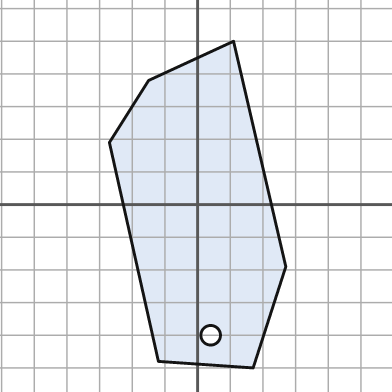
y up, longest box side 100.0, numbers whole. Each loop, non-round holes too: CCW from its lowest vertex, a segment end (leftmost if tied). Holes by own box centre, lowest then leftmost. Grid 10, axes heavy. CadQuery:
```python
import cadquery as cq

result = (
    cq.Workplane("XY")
    .moveTo(17.0, -50.0)
    .lineTo(27.0, -19.0)
    .lineTo(11.0, 50.0)
    .lineTo(-15.0, 38.0)
    .lineTo(-27.0, 19.0)
    .lineTo(-12.0, -48.0)
    .close()
    .moveTo(4.0, -40.0)
    .circle(3.0)
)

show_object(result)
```